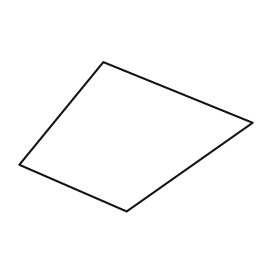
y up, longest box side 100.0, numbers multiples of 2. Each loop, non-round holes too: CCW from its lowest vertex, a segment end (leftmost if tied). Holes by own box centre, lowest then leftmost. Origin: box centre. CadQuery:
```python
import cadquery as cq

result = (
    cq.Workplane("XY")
    .moveTo(-4.0, -32.0)
    .lineTo(50.0, 6.0)
    .lineTo(-14.0, 32.0)
    .lineTo(-50.0, -12.0)
    .close()
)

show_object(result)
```